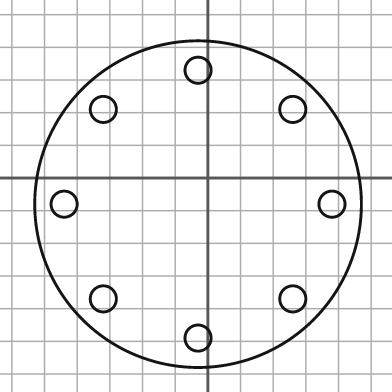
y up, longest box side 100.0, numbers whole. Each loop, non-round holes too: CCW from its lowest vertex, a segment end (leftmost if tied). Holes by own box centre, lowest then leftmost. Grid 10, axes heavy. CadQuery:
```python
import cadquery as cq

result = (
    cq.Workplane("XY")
    .moveTo(-3.0, -8.0)
    .circle(50.0)
    .moveTo(-3.0, -49.0)
    .circle(4.0)
    .moveTo(-32.0, -37.0)
    .circle(4.0)
    .moveTo(26.0, -37.0)
    .circle(4.0)
    .moveTo(-44.0, -8.0)
    .circle(4.0)
    .moveTo(38.0, -8.0)
    .circle(4.0)
    .moveTo(-32.0, 21.0)
    .circle(4.0)
    .moveTo(26.0, 21.0)
    .circle(4.0)
    .moveTo(-3.0, 33.0)
    .circle(4.0)
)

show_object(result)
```